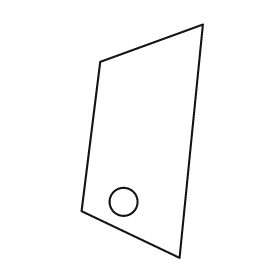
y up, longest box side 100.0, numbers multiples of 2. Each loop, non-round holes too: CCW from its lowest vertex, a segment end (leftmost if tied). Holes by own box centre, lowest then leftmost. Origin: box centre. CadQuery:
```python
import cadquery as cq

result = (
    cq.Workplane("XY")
    .moveTo(16.0, -50.0)
    .lineTo(26.0, 50.0)
    .lineTo(-18.0, 34.0)
    .lineTo(-26.0, -30.0)
    .close()
    .moveTo(-8.0, -26.0)
    .circle(6.0)
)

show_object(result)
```